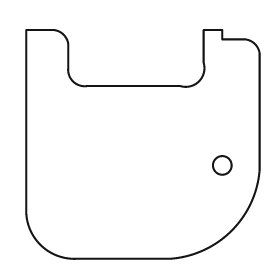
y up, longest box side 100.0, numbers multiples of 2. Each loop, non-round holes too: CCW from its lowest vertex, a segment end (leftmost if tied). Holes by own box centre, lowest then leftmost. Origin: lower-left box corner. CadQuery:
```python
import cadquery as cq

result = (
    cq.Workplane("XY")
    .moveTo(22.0, 0.0)
    .lineTo(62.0, 0.0)
    .threePointArc((88.0, 12.0), (100.0, 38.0))
    .lineTo(100.0, 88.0)
    .threePointArc((98.0, 92.0), (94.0, 94.0))
    .lineTo(84.0, 94.0)
    .lineTo(84.0, 98.0)
    .lineTo(76.0, 98.0)
    .lineTo(76.0, 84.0)
    .threePointArc((74.0, 76.0), (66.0, 74.0))
    .lineTo(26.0, 74.0)
    .threePointArc((20.0, 76.0), (18.0, 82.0))
    .lineTo(18.0, 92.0)
    .threePointArc((16.0, 96.0), (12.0, 98.0))
    .lineTo(0.0, 98.0)
    .lineTo(0.0, 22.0)
    .threePointArc((6.0, 6.0), (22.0, 0.0))
    .close()
    .moveTo(84.0, 40.0)
    .circle(4.0)
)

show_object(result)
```